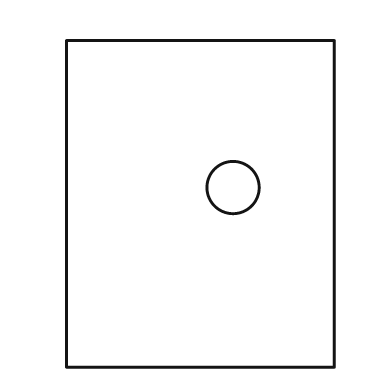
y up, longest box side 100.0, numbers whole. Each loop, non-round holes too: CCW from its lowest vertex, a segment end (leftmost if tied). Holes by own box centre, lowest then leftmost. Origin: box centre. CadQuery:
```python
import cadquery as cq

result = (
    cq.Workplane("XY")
    .moveTo(-41.0, -50.0)
    .lineTo(41.0, -50.0)
    .lineTo(41.0, 50.0)
    .lineTo(-41.0, 50.0)
    .close()
    .moveTo(10.0, 5.0)
    .circle(8.0)
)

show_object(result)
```